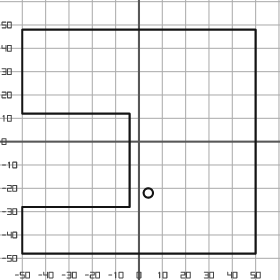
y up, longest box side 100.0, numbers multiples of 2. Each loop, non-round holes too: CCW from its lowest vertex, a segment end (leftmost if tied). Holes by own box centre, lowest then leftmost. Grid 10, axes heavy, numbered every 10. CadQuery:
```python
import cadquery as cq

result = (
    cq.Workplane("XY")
    .moveTo(-50.0, -48.0)
    .lineTo(50.0, -48.0)
    .lineTo(50.0, 48.0)
    .lineTo(-50.0, 48.0)
    .lineTo(-50.0, 12.0)
    .lineTo(-4.0, 12.0)
    .lineTo(-4.0, -28.0)
    .lineTo(-50.0, -28.0)
    .close()
    .moveTo(4.0, -22.0)
    .circle(2.0)
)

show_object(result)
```